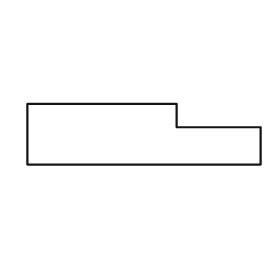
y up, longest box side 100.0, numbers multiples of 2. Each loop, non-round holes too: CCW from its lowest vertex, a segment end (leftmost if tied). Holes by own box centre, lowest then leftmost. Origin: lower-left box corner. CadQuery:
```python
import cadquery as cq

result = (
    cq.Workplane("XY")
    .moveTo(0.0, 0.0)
    .lineTo(100.0, 0.0)
    .lineTo(100.0, 16.0)
    .lineTo(64.0, 16.0)
    .lineTo(64.0, 26.0)
    .lineTo(0.0, 26.0)
    .close()
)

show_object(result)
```